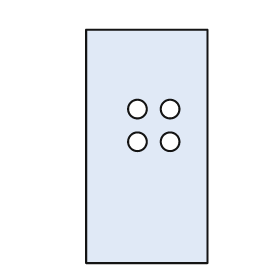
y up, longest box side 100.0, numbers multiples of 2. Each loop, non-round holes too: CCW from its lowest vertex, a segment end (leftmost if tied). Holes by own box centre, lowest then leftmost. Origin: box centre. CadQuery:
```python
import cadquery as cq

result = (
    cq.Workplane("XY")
    .moveTo(-26.0, -50.0)
    .lineTo(26.0, -50.0)
    .lineTo(26.0, 50.0)
    .lineTo(-26.0, 50.0)
    .close()
    .moveTo(-4.0, 2.0)
    .circle(4.0)
    .moveTo(10.0, 2.0)
    .circle(4.0)
    .moveTo(-4.0, 16.0)
    .circle(4.0)
    .moveTo(10.0, 16.0)
    .circle(4.0)
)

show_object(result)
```